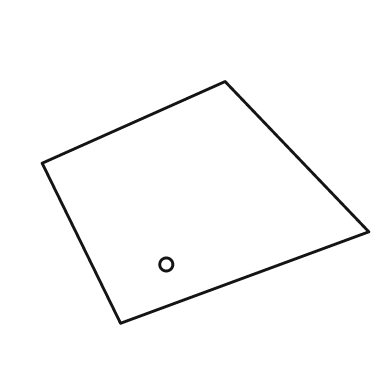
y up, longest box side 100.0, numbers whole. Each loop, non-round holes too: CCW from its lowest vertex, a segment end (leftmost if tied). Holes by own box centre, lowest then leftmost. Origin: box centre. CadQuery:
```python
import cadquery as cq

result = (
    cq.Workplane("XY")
    .moveTo(-26.0, -37.0)
    .lineTo(50.0, -9.0)
    .lineTo(6.0, 37.0)
    .lineTo(-50.0, 12.0)
    .close()
    .moveTo(-12.0, -19.0)
    .circle(2.0)
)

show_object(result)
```